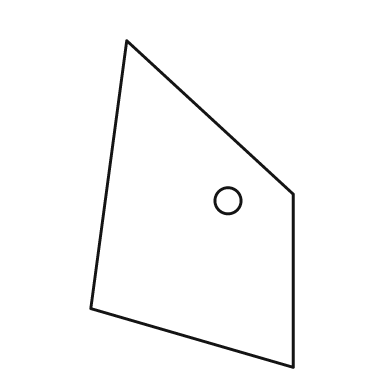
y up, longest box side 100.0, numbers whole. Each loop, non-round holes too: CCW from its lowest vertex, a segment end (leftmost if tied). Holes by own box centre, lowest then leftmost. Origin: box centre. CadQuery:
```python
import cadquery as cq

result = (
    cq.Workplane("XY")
    .moveTo(31.0, -50.0)
    .lineTo(31.0, 3.0)
    .lineTo(-20.0, 50.0)
    .lineTo(-31.0, -32.0)
    .close()
    .moveTo(11.0, 1.0)
    .circle(4.0)
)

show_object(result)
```